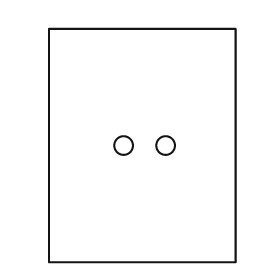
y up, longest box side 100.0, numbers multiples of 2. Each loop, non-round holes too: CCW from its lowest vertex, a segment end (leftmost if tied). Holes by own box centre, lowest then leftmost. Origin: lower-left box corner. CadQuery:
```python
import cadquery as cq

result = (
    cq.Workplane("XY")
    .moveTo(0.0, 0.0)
    .lineTo(80.0, 0.0)
    .lineTo(80.0, 100.0)
    .lineTo(0.0, 100.0)
    .close()
    .moveTo(32.0, 50.0)
    .circle(4.0)
    .moveTo(50.0, 50.0)
    .circle(4.0)
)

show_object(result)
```